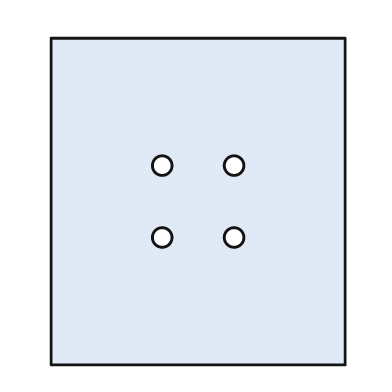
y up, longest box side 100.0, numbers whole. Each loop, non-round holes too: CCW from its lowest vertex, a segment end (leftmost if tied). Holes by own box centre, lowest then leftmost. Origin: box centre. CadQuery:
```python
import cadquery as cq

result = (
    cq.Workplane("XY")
    .moveTo(-45.0, -50.0)
    .lineTo(45.0, -50.0)
    .lineTo(45.0, 50.0)
    .lineTo(-45.0, 50.0)
    .close()
    .moveTo(-11.0, -11.0)
    .circle(3.0)
    .moveTo(11.0, -11.0)
    .circle(3.0)
    .moveTo(-11.0, 11.0)
    .circle(3.0)
    .moveTo(11.0, 11.0)
    .circle(3.0)
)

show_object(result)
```